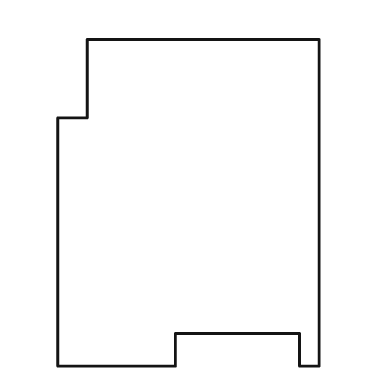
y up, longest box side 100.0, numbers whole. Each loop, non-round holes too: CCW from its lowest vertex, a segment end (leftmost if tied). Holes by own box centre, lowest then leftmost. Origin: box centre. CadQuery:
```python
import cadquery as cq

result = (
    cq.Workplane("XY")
    .moveTo(-40.0, -50.0)
    .lineTo(-4.0, -50.0)
    .lineTo(-4.0, -40.0)
    .lineTo(34.0, -40.0)
    .lineTo(34.0, -50.0)
    .lineTo(40.0, -50.0)
    .lineTo(40.0, 50.0)
    .lineTo(-31.0, 50.0)
    .lineTo(-31.0, 26.0)
    .lineTo(-40.0, 26.0)
    .close()
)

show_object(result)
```